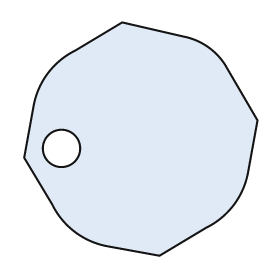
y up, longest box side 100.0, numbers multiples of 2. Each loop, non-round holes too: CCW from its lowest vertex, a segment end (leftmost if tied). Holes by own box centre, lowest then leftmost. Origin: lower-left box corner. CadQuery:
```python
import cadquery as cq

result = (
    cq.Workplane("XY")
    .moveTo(58.0, 0.0)
    .lineTo(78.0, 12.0)
    .threePointArc((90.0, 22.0), (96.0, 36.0))
    .lineTo(100.0, 58.0)
    .lineTo(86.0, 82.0)
    .threePointArc((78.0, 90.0), (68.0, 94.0))
    .lineTo(42.0, 100.0)
    .lineTo(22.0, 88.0)
    .threePointArc((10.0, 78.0), (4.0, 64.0))
    .lineTo(0.0, 42.0)
    .lineTo(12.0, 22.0)
    .threePointArc((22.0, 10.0), (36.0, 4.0))
    .close()
    .moveTo(16.0, 46.0)
    .circle(8.0)
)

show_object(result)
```